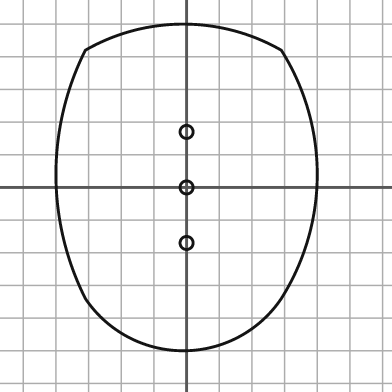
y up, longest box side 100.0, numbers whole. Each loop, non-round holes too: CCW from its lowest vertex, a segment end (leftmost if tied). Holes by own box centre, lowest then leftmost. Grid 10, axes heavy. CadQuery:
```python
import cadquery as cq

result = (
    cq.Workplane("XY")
    .moveTo(-31.0, -34.0)
    .threePointArc((-1.0, -50.0), (29.0, -34.0))
    .threePointArc((40.0, 4.0), (29.0, 42.0))
    .threePointArc((-1.0, 50.0), (-31.0, 42.0))
    .threePointArc((-40.0, 4.0), (-31.0, -34.0))
    .close()
    .moveTo(0.0, -17.0)
    .circle(2.0)
    .moveTo(0.0, 0.0)
    .circle(2.0)
    .moveTo(0.0, 17.0)
    .circle(2.0)
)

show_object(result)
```